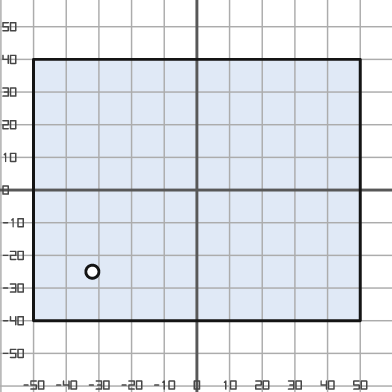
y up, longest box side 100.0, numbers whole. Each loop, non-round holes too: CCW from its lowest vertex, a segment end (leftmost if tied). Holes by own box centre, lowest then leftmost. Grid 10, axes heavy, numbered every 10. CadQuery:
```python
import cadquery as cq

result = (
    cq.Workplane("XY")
    .moveTo(-50.0, -40.0)
    .lineTo(50.0, -40.0)
    .lineTo(50.0, 40.0)
    .lineTo(-50.0, 40.0)
    .close()
    .moveTo(-32.0, -25.0)
    .circle(2.0)
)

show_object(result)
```